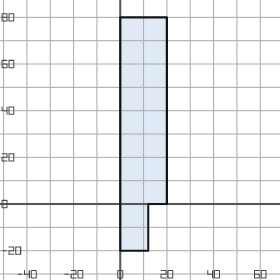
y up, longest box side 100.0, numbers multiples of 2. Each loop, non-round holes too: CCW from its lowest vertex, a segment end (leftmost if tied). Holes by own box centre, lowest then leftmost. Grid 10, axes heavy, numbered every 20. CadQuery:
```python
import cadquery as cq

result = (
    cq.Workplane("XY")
    .moveTo(0.0, -20.0)
    .lineTo(12.0, -20.0)
    .lineTo(12.0, 0.0)
    .lineTo(20.0, 0.0)
    .lineTo(20.0, 80.0)
    .lineTo(0.0, 80.0)
    .close()
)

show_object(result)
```